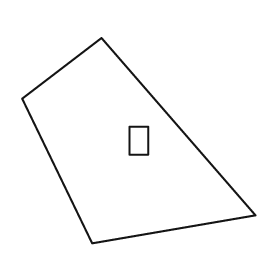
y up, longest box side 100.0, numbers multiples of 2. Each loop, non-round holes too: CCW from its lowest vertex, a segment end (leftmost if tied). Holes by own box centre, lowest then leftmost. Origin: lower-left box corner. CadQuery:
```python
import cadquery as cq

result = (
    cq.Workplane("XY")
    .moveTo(30.0, 0.0)
    .lineTo(100.0, 12.0)
    .lineTo(34.0, 88.0)
    .lineTo(0.0, 62.0)
    .close()
    .moveTo(46.0, 38.0)
    .lineTo(54.0, 38.0)
    .lineTo(54.0, 50.0)
    .lineTo(46.0, 50.0)
    .close()
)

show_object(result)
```